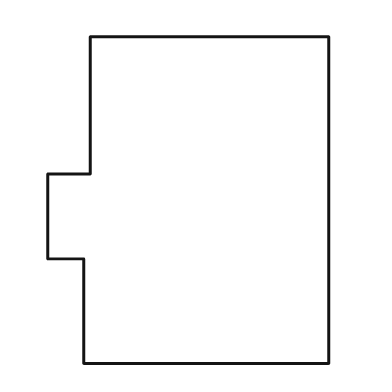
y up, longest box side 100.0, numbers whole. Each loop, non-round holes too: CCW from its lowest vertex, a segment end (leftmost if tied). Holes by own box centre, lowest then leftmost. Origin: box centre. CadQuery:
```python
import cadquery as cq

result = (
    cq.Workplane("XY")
    .moveTo(-32.0, -50.0)
    .lineTo(43.0, -50.0)
    .lineTo(43.0, 50.0)
    .lineTo(-30.0, 50.0)
    .lineTo(-30.0, 8.0)
    .lineTo(-43.0, 8.0)
    .lineTo(-43.0, -18.0)
    .lineTo(-32.0, -18.0)
    .close()
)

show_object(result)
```